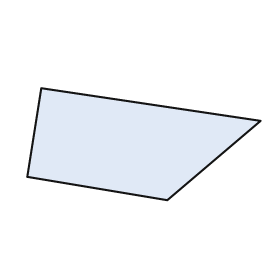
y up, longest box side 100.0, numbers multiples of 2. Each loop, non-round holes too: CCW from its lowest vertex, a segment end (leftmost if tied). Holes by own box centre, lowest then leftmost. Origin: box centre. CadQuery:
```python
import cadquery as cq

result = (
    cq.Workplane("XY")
    .moveTo(10.0, -24.0)
    .lineTo(50.0, 10.0)
    .lineTo(-44.0, 24.0)
    .lineTo(-50.0, -14.0)
    .close()
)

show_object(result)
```